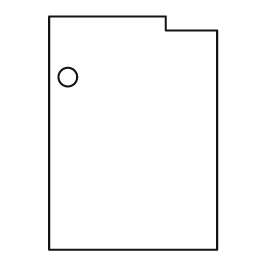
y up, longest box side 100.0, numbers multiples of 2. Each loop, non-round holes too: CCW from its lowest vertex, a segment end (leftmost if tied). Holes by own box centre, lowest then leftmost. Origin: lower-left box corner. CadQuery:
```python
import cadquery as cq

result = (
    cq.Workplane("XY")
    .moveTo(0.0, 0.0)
    .lineTo(72.0, 0.0)
    .lineTo(72.0, 94.0)
    .lineTo(50.0, 94.0)
    .lineTo(50.0, 100.0)
    .lineTo(0.0, 100.0)
    .close()
    .moveTo(8.0, 74.0)
    .circle(4.0)
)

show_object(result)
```